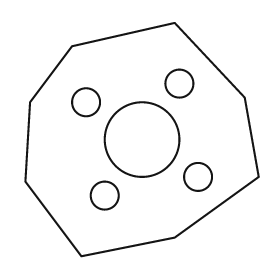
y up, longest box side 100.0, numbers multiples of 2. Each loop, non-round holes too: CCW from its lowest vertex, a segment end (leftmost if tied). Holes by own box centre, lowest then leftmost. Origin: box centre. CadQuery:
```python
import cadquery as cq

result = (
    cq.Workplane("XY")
    .moveTo(-26.0, -50.0)
    .lineTo(14.0, -42.0)
    .lineTo(50.0, -16.0)
    .lineTo(44.0, 18.0)
    .lineTo(14.0, 50.0)
    .lineTo(-30.0, 40.0)
    .lineTo(-48.0, 16.0)
    .lineTo(-50.0, -18.0)
    .close()
    .moveTo(-16.0, -24.0)
    .circle(6.0)
    .moveTo(24.0, -16.0)
    .circle(6.0)
    .moveTo(0.0, 0.0)
    .circle(16.0)
    .moveTo(-24.0, 16.0)
    .circle(6.0)
    .moveTo(16.0, 24.0)
    .circle(6.0)
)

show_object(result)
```